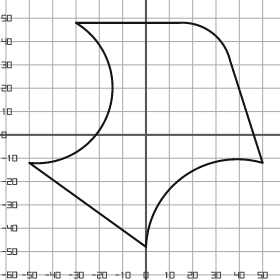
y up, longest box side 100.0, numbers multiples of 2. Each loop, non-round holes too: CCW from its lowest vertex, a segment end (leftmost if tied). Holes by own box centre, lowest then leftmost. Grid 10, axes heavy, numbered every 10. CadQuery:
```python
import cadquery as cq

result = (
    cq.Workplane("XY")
    .moveTo(0.0, -48.0)
    .threePointArc((16.0, -18.0), (50.0, -12.0))
    .lineTo(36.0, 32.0)
    .threePointArc((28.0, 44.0), (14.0, 48.0))
    .lineTo(-30.0, 48.0)
    .threePointArc((-16.0, 10.0), (-50.0, -12.0))
    .close()
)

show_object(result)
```